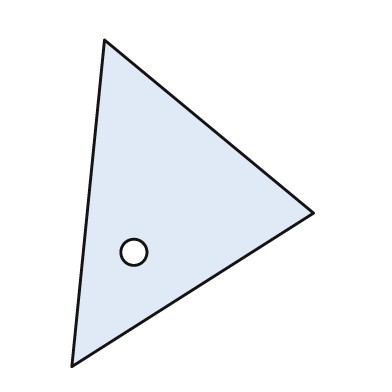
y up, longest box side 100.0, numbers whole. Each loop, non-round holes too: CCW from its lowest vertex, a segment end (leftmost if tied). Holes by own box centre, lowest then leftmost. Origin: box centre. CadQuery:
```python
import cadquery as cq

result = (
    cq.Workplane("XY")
    .moveTo(-37.0, -50.0)
    .lineTo(37.0, -3.0)
    .lineTo(-27.0, 50.0)
    .close()
    .moveTo(-18.0, -15.0)
    .circle(4.0)
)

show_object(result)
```